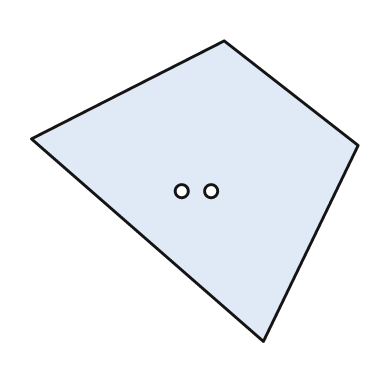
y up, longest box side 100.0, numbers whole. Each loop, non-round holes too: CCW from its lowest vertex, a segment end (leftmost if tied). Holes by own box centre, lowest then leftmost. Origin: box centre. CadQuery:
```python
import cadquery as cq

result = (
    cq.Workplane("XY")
    .moveTo(21.0, -46.0)
    .lineTo(50.0, 14.0)
    .lineTo(9.0, 46.0)
    .lineTo(-50.0, 16.0)
    .close()
    .moveTo(-4.0, 0.0)
    .circle(2.0)
    .moveTo(5.0, 0.0)
    .circle(2.0)
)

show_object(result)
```